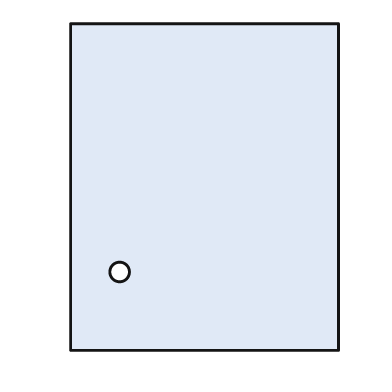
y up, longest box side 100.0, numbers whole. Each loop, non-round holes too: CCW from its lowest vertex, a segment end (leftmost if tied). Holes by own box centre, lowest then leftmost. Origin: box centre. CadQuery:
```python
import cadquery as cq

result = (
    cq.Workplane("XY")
    .moveTo(-41.0, -50.0)
    .lineTo(41.0, -50.0)
    .lineTo(41.0, 50.0)
    .lineTo(-41.0, 50.0)
    .close()
    .moveTo(-26.0, -26.0)
    .circle(3.0)
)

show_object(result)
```